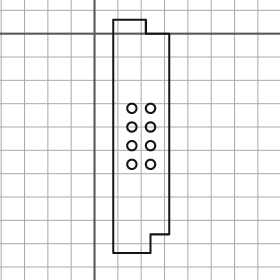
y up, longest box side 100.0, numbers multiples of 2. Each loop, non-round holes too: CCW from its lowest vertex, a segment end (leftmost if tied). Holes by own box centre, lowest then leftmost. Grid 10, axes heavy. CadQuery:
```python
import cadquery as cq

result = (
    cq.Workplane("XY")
    .moveTo(8.0, -94.0)
    .lineTo(24.0, -94.0)
    .lineTo(24.0, -86.0)
    .lineTo(32.0, -86.0)
    .lineTo(32.0, 0.0)
    .lineTo(22.0, 0.0)
    .lineTo(22.0, 6.0)
    .lineTo(8.0, 6.0)
    .close()
    .moveTo(16.0, -56.0)
    .circle(2.0)
    .moveTo(24.0, -56.0)
    .circle(2.0)
    .moveTo(16.0, -48.0)
    .circle(2.0)
    .moveTo(24.0, -48.0)
    .circle(2.0)
    .moveTo(16.0, -40.0)
    .circle(2.0)
    .moveTo(24.0, -40.0)
    .circle(2.0)
    .moveTo(16.0, -32.0)
    .circle(2.0)
    .moveTo(24.0, -32.0)
    .circle(2.0)
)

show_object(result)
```